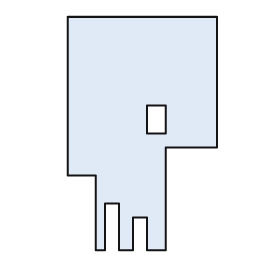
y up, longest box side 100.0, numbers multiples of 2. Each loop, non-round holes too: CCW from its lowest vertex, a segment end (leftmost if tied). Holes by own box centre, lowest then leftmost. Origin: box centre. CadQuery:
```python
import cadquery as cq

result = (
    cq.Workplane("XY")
    .moveTo(-20.0, -50.0)
    .lineTo(-16.0, -50.0)
    .lineTo(-16.0, -30.0)
    .lineTo(-10.0, -30.0)
    .lineTo(-10.0, -50.0)
    .lineTo(-4.0, -50.0)
    .lineTo(-4.0, -36.0)
    .lineTo(2.0, -36.0)
    .lineTo(2.0, -50.0)
    .lineTo(10.0, -50.0)
    .lineTo(10.0, -6.0)
    .lineTo(32.0, -6.0)
    .lineTo(32.0, 50.0)
    .lineTo(-32.0, 50.0)
    .lineTo(-32.0, -18.0)
    .lineTo(-20.0, -18.0)
    .close()
    .moveTo(2.0, 0.0)
    .lineTo(10.0, 0.0)
    .lineTo(10.0, 12.0)
    .lineTo(2.0, 12.0)
    .close()
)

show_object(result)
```